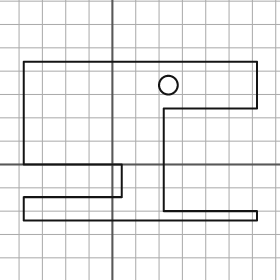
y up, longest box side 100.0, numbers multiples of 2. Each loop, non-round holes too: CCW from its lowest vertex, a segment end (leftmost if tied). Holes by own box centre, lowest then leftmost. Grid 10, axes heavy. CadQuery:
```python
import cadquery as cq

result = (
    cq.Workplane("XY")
    .moveTo(-38.0, -24.0)
    .lineTo(62.0, -24.0)
    .lineTo(62.0, -20.0)
    .lineTo(22.0, -20.0)
    .lineTo(22.0, 24.0)
    .lineTo(62.0, 24.0)
    .lineTo(62.0, 44.0)
    .lineTo(-38.0, 44.0)
    .lineTo(-38.0, 0.0)
    .lineTo(4.0, 0.0)
    .lineTo(4.0, -14.0)
    .lineTo(-38.0, -14.0)
    .close()
    .moveTo(24.0, 34.0)
    .circle(4.0)
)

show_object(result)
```